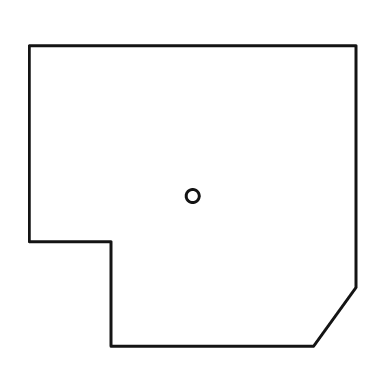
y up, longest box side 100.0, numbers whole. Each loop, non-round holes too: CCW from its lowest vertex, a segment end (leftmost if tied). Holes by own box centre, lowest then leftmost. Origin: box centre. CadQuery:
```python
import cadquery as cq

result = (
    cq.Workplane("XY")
    .moveTo(-25.0, -46.0)
    .lineTo(37.0, -46.0)
    .lineTo(50.0, -28.0)
    .lineTo(50.0, 46.0)
    .lineTo(-50.0, 46.0)
    .lineTo(-50.0, -14.0)
    .lineTo(-25.0, -14.0)
    .close()
    .moveTo(0.0, 0.0)
    .circle(2.0)
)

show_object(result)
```